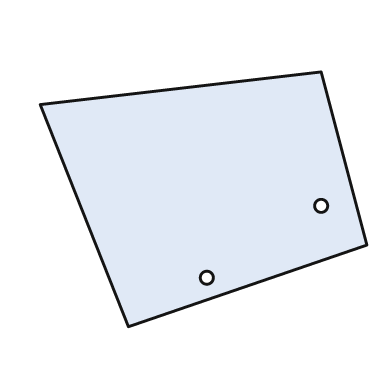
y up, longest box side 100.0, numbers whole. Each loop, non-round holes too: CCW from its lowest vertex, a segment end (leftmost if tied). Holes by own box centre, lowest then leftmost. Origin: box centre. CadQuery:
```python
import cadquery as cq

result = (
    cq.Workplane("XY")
    .moveTo(-23.0, -39.0)
    .lineTo(50.0, -14.0)
    .lineTo(36.0, 39.0)
    .lineTo(-50.0, 29.0)
    .close()
    .moveTo(1.0, -24.0)
    .circle(2.0)
    .moveTo(36.0, -2.0)
    .circle(2.0)
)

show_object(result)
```